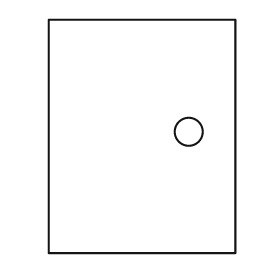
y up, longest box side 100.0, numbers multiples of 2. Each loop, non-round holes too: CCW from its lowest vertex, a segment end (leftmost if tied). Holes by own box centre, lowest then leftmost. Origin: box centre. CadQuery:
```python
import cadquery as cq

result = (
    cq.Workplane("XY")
    .moveTo(-40.0, -50.0)
    .lineTo(40.0, -50.0)
    .lineTo(40.0, 50.0)
    .lineTo(-40.0, 50.0)
    .close()
    .moveTo(20.0, 2.0)
    .circle(6.0)
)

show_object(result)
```